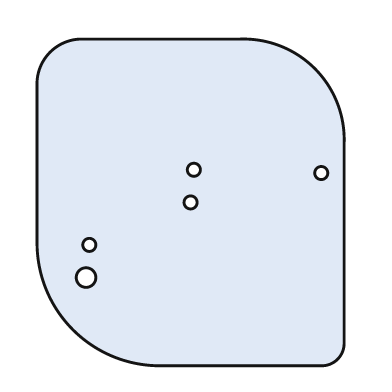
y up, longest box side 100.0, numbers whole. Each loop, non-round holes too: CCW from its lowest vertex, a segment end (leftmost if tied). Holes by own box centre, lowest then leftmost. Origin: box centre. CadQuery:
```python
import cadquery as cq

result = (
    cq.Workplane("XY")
    .moveTo(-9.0, -50.0)
    .lineTo(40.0, -50.0)
    .threePointArc((45.0, -48.0), (47.0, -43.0))
    .lineTo(47.0, 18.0)
    .threePointArc((38.0, 41.0), (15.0, 50.0))
    .lineTo(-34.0, 50.0)
    .threePointArc((-43.0, 46.0), (-47.0, 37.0))
    .lineTo(-47.0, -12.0)
    .threePointArc((-36.0, -39.0), (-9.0, -50.0))
    .close()
    .moveTo(-32.0, -23.0)
    .circle(3.0)
    .moveTo(-31.0, -13.0)
    .circle(2.0)
    .moveTo(0.0, 0.0)
    .circle(2.0)
    .moveTo(40.0, 9.0)
    .circle(2.0)
    .moveTo(1.0, 10.0)
    .circle(2.0)
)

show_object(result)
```